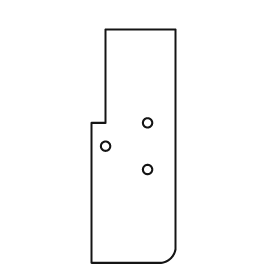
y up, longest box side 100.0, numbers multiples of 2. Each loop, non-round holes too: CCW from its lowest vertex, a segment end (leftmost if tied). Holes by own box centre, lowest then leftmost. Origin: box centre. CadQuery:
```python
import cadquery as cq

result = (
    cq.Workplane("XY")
    .moveTo(-18.0, -50.0)
    .lineTo(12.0, -50.0)
    .threePointArc((16.0, -48.0), (18.0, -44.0))
    .lineTo(18.0, 50.0)
    .lineTo(-12.0, 50.0)
    .lineTo(-12.0, 10.0)
    .lineTo(-18.0, 10.0)
    .close()
    .moveTo(6.0, -10.0)
    .circle(2.0)
    .moveTo(-12.0, 0.0)
    .circle(2.0)
    .moveTo(6.0, 10.0)
    .circle(2.0)
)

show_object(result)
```